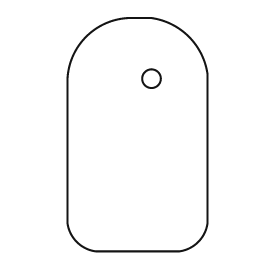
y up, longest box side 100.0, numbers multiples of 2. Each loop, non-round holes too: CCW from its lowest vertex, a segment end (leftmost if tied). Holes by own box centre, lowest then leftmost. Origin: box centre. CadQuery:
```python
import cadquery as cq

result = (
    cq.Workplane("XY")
    .moveTo(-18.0, -50.0)
    .lineTo(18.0, -50.0)
    .threePointArc((26.0, -46.0), (30.0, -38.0))
    .lineTo(30.0, 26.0)
    .threePointArc((22.0, 42.0), (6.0, 50.0))
    .lineTo(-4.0, 50.0)
    .threePointArc((-22.0, 42.0), (-30.0, 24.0))
    .lineTo(-30.0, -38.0)
    .threePointArc((-26.0, -46.0), (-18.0, -50.0))
    .close()
    .moveTo(6.0, 24.0)
    .circle(4.0)
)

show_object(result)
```